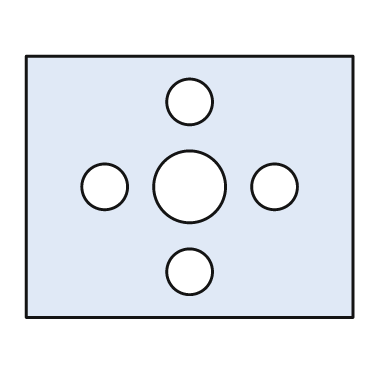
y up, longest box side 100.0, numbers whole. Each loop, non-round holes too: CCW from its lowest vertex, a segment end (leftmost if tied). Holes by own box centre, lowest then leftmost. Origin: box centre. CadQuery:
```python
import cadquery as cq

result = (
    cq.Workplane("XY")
    .moveTo(-50.0, -40.0)
    .lineTo(50.0, -40.0)
    .lineTo(50.0, 40.0)
    .lineTo(-50.0, 40.0)
    .close()
    .moveTo(0.0, -26.0)
    .circle(7.0)
    .moveTo(-26.0, 0.0)
    .circle(7.0)
    .moveTo(0.0, 0.0)
    .circle(11.0)
    .moveTo(26.0, 0.0)
    .circle(7.0)
    .moveTo(0.0, 26.0)
    .circle(7.0)
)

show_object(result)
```